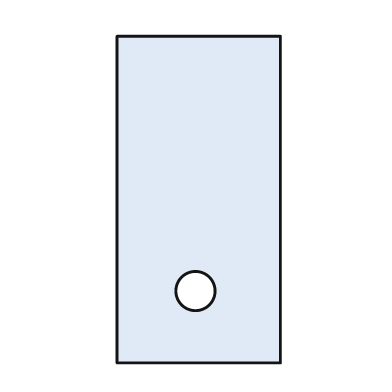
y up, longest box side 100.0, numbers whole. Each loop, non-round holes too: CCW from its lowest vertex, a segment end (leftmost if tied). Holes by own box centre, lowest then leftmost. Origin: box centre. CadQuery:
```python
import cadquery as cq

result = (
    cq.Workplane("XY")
    .moveTo(-25.0, -50.0)
    .lineTo(25.0, -50.0)
    .lineTo(25.0, 50.0)
    .lineTo(-25.0, 50.0)
    .close()
    .moveTo(-1.0, -28.0)
    .circle(6.0)
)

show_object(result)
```